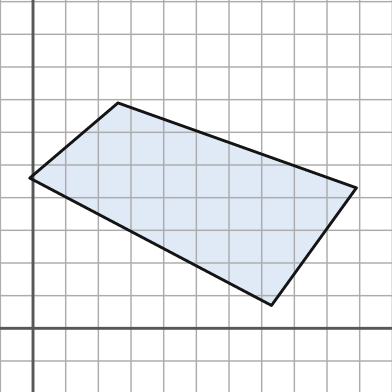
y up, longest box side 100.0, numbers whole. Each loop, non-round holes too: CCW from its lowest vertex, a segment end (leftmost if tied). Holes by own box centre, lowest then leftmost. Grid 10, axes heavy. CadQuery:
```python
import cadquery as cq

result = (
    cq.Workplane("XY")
    .moveTo(73.0, 7.0)
    .lineTo(99.0, 43.0)
    .lineTo(26.0, 69.0)
    .lineTo(-1.0, 46.0)
    .close()
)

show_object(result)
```